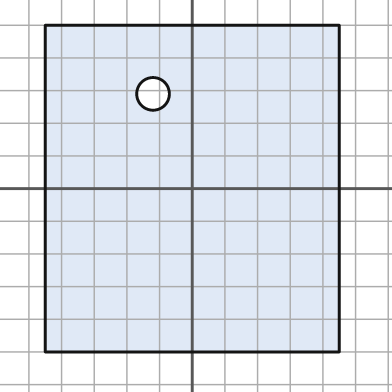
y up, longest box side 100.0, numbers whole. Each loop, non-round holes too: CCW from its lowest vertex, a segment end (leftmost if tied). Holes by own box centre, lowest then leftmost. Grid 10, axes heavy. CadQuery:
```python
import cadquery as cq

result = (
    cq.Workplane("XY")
    .moveTo(-45.0, -50.0)
    .lineTo(45.0, -50.0)
    .lineTo(45.0, 50.0)
    .lineTo(-45.0, 50.0)
    .close()
    .moveTo(-12.0, 29.0)
    .circle(5.0)
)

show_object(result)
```